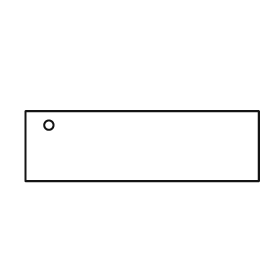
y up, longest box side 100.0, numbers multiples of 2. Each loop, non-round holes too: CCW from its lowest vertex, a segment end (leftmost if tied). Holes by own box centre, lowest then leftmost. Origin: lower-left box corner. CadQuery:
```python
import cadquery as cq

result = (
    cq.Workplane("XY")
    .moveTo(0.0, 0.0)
    .lineTo(100.0, 0.0)
    .lineTo(100.0, 30.0)
    .lineTo(0.0, 30.0)
    .close()
    .moveTo(10.0, 24.0)
    .circle(2.0)
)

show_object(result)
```